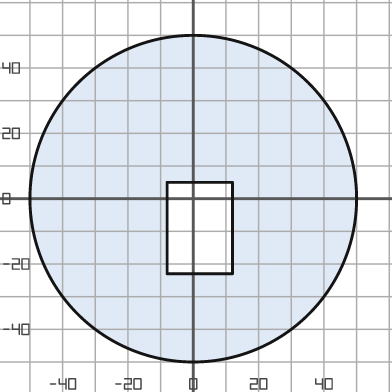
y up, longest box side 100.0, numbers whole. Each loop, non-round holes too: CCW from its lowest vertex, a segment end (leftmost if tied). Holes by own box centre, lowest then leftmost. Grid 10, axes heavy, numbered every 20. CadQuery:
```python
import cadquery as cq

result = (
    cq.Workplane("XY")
    .moveTo(0.0, 0.0)
    .circle(50.0)
    .moveTo(-8.0, -23.0)
    .lineTo(12.0, -23.0)
    .lineTo(12.0, 5.0)
    .lineTo(-8.0, 5.0)
    .close()
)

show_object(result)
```